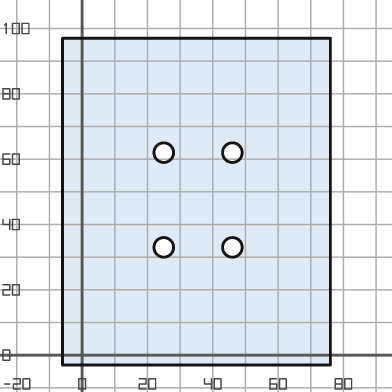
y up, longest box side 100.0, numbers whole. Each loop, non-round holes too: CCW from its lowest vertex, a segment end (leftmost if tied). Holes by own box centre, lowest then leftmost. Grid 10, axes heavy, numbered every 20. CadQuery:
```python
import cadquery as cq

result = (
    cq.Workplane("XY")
    .moveTo(-6.0, -3.0)
    .lineTo(76.0, -3.0)
    .lineTo(76.0, 97.0)
    .lineTo(-6.0, 97.0)
    .close()
    .moveTo(25.0, 33.0)
    .circle(3.0)
    .moveTo(46.0, 33.0)
    .circle(3.0)
    .moveTo(25.0, 62.0)
    .circle(3.0)
    .moveTo(46.0, 62.0)
    .circle(3.0)
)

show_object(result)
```